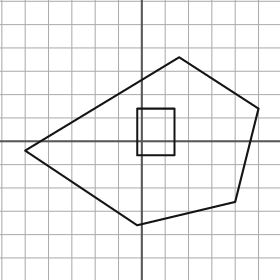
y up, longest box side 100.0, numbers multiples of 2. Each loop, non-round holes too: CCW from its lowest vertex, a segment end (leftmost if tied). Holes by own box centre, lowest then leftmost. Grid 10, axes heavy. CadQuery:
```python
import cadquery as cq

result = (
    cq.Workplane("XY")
    .moveTo(-2.0, -36.0)
    .lineTo(40.0, -26.0)
    .lineTo(50.0, 14.0)
    .lineTo(16.0, 36.0)
    .lineTo(-50.0, -4.0)
    .close()
    .moveTo(-2.0, -6.0)
    .lineTo(14.0, -6.0)
    .lineTo(14.0, 14.0)
    .lineTo(-2.0, 14.0)
    .close()
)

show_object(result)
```